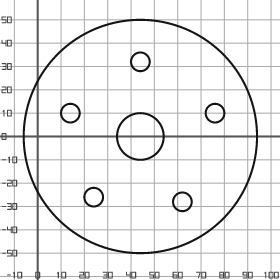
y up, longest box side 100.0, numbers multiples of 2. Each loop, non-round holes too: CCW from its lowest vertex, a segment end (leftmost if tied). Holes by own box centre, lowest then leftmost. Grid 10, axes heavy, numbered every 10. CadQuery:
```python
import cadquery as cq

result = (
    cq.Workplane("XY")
    .moveTo(44.0, 0.0)
    .circle(50.0)
    .moveTo(62.0, -28.0)
    .circle(4.0)
    .moveTo(24.0, -26.0)
    .circle(4.0)
    .moveTo(44.0, 0.0)
    .circle(10.0)
    .moveTo(14.0, 10.0)
    .circle(4.0)
    .moveTo(76.0, 10.0)
    .circle(4.0)
    .moveTo(44.0, 32.0)
    .circle(4.0)
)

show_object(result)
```